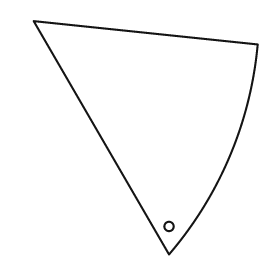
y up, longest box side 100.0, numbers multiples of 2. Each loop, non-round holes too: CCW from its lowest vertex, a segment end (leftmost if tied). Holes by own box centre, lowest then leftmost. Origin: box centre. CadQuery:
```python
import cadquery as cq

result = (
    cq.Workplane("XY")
    .moveTo(10.0, -50.0)
    .threePointArc((36.0, -8.0), (48.0, 40.0))
    .lineTo(-48.0, 50.0)
    .close()
    .moveTo(10.0, -38.0)
    .circle(2.0)
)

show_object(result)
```